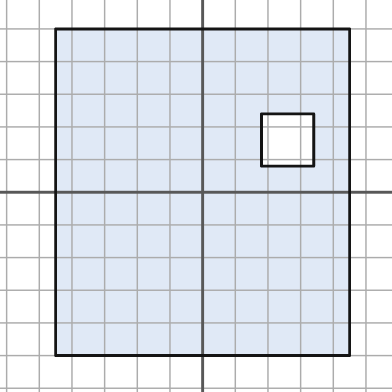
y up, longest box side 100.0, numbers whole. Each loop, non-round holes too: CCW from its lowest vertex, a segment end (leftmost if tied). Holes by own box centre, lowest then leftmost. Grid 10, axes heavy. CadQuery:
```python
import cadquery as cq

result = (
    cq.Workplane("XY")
    .moveTo(-45.0, -50.0)
    .lineTo(45.0, -50.0)
    .lineTo(45.0, 50.0)
    .lineTo(-45.0, 50.0)
    .close()
    .moveTo(18.0, 8.0)
    .lineTo(34.0, 8.0)
    .lineTo(34.0, 24.0)
    .lineTo(18.0, 24.0)
    .close()
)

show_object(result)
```